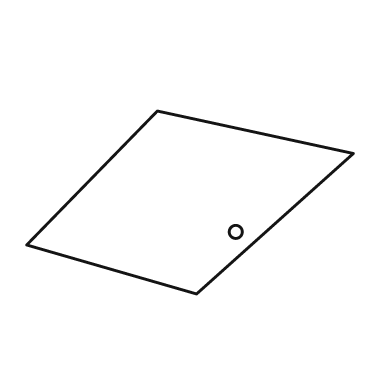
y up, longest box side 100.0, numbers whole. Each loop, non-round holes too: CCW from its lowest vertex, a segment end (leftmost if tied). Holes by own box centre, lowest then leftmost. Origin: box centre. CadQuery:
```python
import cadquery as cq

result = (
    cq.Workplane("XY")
    .moveTo(2.0, -28.0)
    .lineTo(50.0, 15.0)
    .lineTo(-10.0, 28.0)
    .lineTo(-50.0, -13.0)
    .close()
    .moveTo(14.0, -9.0)
    .circle(2.0)
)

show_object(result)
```